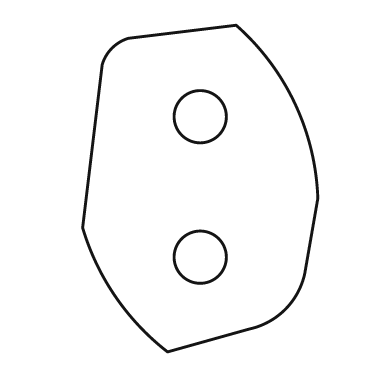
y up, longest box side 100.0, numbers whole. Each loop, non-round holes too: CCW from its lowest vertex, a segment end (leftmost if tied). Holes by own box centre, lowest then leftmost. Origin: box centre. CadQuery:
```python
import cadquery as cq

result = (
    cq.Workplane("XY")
    .moveTo(-10.0, -50.0)
    .lineTo(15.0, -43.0)
    .threePointArc((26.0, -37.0), (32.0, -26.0))
    .lineTo(36.0, -3.0)
    .threePointArc((29.0, 26.0), (11.0, 50.0))
    .lineTo(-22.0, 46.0)
    .threePointArc((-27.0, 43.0), (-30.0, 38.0))
    .lineTo(-36.0, -12.0)
    .threePointArc((-26.0, -33.0), (-10.0, -50.0))
    .close()
    .moveTo(0.0, -21.0)
    .circle(8.0)
    .moveTo(0.0, 22.0)
    .circle(8.0)
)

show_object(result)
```